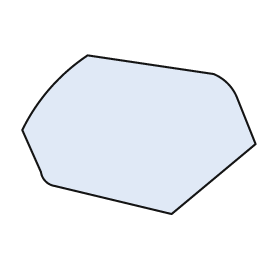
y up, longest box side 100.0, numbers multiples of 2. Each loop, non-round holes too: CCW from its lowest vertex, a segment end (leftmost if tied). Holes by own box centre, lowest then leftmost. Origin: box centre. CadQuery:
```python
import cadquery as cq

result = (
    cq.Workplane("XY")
    .moveTo(14.0, -34.0)
    .lineTo(50.0, -4.0)
    .lineTo(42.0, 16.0)
    .threePointArc((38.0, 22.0), (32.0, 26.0))
    .lineTo(-22.0, 34.0)
    .threePointArc((-38.0, 20.0), (-50.0, 2.0))
    .lineTo(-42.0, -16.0)
    .threePointArc((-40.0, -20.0), (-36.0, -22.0))
    .close()
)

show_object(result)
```